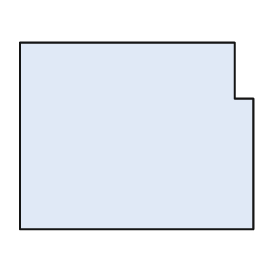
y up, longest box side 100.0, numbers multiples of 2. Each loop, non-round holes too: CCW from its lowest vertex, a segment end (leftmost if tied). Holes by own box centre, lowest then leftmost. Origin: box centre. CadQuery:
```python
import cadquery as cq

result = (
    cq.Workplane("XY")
    .moveTo(-50.0, -40.0)
    .lineTo(50.0, -40.0)
    .lineTo(50.0, 16.0)
    .lineTo(42.0, 16.0)
    .lineTo(42.0, 40.0)
    .lineTo(-50.0, 40.0)
    .close()
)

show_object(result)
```